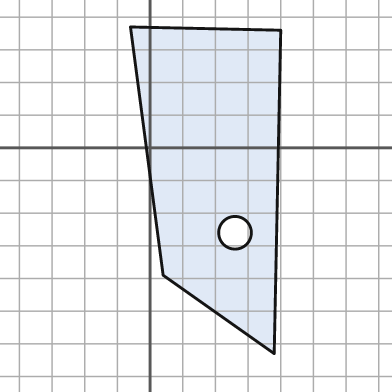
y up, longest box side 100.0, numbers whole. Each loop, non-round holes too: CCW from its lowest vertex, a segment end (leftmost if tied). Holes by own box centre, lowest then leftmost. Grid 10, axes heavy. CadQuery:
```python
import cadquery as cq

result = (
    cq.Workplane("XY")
    .moveTo(38.0, -63.0)
    .lineTo(40.0, 36.0)
    .lineTo(-6.0, 37.0)
    .lineTo(4.0, -39.0)
    .close()
    .moveTo(26.0, -26.0)
    .circle(5.0)
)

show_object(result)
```